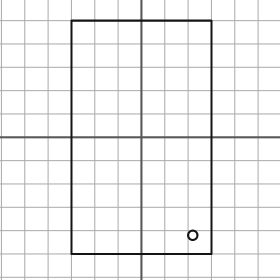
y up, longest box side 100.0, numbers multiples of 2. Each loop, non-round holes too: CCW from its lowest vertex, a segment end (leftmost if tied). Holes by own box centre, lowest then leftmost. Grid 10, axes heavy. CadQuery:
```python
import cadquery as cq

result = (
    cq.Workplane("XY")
    .moveTo(-30.0, -50.0)
    .lineTo(30.0, -50.0)
    .lineTo(30.0, 50.0)
    .lineTo(-30.0, 50.0)
    .close()
    .moveTo(22.0, -42.0)
    .circle(2.0)
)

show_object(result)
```